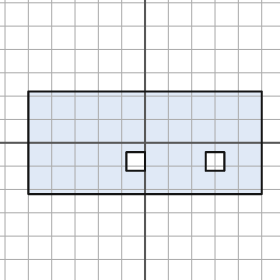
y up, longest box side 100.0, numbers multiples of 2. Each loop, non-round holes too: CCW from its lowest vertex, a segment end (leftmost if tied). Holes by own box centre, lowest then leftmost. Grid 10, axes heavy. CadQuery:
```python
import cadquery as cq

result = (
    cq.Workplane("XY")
    .moveTo(-50.0, -22.0)
    .lineTo(50.0, -22.0)
    .lineTo(50.0, 22.0)
    .lineTo(-50.0, 22.0)
    .close()
    .moveTo(-8.0, -12.0)
    .lineTo(0.0, -12.0)
    .lineTo(0.0, -4.0)
    .lineTo(-8.0, -4.0)
    .close()
    .moveTo(26.0, -12.0)
    .lineTo(34.0, -12.0)
    .lineTo(34.0, -4.0)
    .lineTo(26.0, -4.0)
    .close()
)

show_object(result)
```